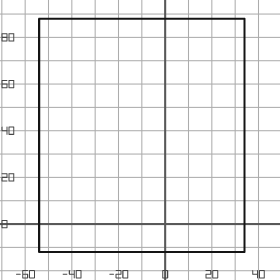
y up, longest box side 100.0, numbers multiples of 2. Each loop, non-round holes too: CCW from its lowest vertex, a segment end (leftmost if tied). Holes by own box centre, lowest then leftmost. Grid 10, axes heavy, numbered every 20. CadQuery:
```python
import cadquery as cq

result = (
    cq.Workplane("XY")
    .moveTo(-54.0, -12.0)
    .lineTo(34.0, -12.0)
    .lineTo(34.0, 88.0)
    .lineTo(-54.0, 88.0)
    .close()
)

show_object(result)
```